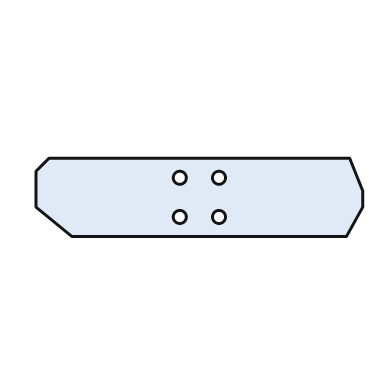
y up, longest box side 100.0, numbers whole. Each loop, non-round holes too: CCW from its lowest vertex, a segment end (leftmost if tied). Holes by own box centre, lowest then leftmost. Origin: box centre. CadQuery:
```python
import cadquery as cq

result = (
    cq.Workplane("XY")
    .moveTo(-39.0, -12.0)
    .lineTo(45.0, -12.0)
    .lineTo(50.0, -3.0)
    .lineTo(50.0, 2.0)
    .lineTo(46.0, 12.0)
    .lineTo(-46.0, 12.0)
    .lineTo(-50.0, 8.0)
    .lineTo(-50.0, -3.0)
    .close()
    .moveTo(-6.0, -6.0)
    .circle(2.0)
    .moveTo(6.0, -6.0)
    .circle(2.0)
    .moveTo(-6.0, 6.0)
    .circle(2.0)
    .moveTo(6.0, 6.0)
    .circle(2.0)
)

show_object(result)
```